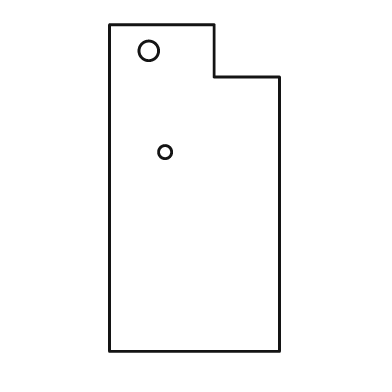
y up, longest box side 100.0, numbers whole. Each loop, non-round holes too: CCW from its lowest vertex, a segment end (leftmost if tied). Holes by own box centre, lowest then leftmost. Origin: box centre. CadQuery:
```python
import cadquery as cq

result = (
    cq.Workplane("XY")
    .moveTo(-26.0, -50.0)
    .lineTo(26.0, -50.0)
    .lineTo(26.0, 34.0)
    .lineTo(6.0, 34.0)
    .lineTo(6.0, 50.0)
    .lineTo(-26.0, 50.0)
    .close()
    .moveTo(-9.0, 11.0)
    .circle(2.0)
    .moveTo(-14.0, 42.0)
    .circle(3.0)
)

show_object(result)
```